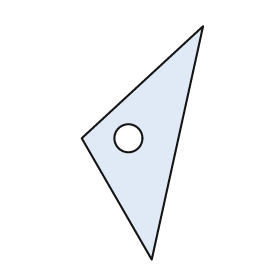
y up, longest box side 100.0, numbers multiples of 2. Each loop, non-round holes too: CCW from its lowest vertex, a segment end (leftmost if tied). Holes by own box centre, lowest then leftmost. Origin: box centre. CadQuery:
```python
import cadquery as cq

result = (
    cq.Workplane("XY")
    .moveTo(4.0, -50.0)
    .lineTo(26.0, 50.0)
    .lineTo(-26.0, 2.0)
    .close()
    .moveTo(-6.0, 2.0)
    .circle(6.0)
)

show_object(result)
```